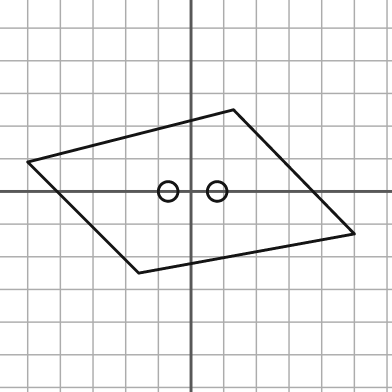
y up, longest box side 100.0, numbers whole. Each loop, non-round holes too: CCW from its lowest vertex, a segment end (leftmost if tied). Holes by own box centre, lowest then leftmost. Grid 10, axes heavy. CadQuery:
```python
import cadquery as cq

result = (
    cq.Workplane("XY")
    .moveTo(-16.0, -25.0)
    .lineTo(50.0, -13.0)
    .lineTo(13.0, 25.0)
    .lineTo(-50.0, 9.0)
    .close()
    .moveTo(-7.0, 0.0)
    .circle(3.0)
    .moveTo(8.0, 0.0)
    .circle(3.0)
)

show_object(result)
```